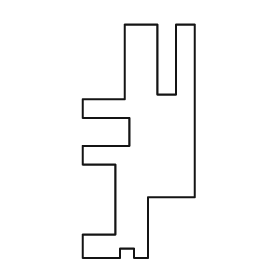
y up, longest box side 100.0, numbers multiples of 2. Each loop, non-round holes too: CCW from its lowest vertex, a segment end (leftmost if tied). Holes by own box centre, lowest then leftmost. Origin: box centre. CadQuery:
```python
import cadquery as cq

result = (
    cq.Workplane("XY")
    .moveTo(-24.0, -50.0)
    .lineTo(-8.0, -50.0)
    .lineTo(-8.0, -46.0)
    .lineTo(-2.0, -46.0)
    .lineTo(-2.0, -50.0)
    .lineTo(4.0, -50.0)
    .lineTo(4.0, -24.0)
    .lineTo(24.0, -24.0)
    .lineTo(24.0, 50.0)
    .lineTo(16.0, 50.0)
    .lineTo(16.0, 20.0)
    .lineTo(8.0, 20.0)
    .lineTo(8.0, 50.0)
    .lineTo(-6.0, 50.0)
    .lineTo(-6.0, 18.0)
    .lineTo(-24.0, 18.0)
    .lineTo(-24.0, 10.0)
    .lineTo(-4.0, 10.0)
    .lineTo(-4.0, -2.0)
    .lineTo(-24.0, -2.0)
    .lineTo(-24.0, -10.0)
    .lineTo(-10.0, -10.0)
    .lineTo(-10.0, -40.0)
    .lineTo(-24.0, -40.0)
    .close()
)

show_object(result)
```